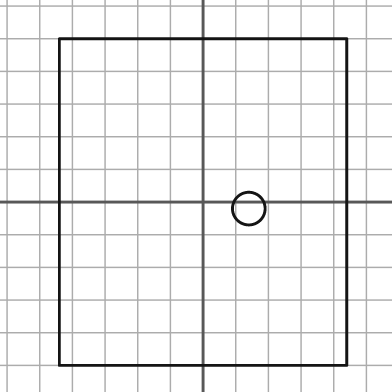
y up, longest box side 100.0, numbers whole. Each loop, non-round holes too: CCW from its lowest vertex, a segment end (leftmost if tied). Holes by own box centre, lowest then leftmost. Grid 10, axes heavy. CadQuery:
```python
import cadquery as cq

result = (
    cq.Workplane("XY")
    .moveTo(-44.0, -50.0)
    .lineTo(44.0, -50.0)
    .lineTo(44.0, 50.0)
    .lineTo(-44.0, 50.0)
    .close()
    .moveTo(14.0, -2.0)
    .circle(5.0)
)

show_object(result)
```